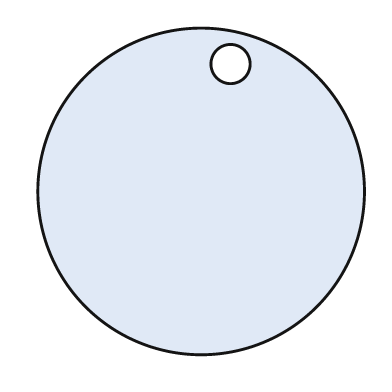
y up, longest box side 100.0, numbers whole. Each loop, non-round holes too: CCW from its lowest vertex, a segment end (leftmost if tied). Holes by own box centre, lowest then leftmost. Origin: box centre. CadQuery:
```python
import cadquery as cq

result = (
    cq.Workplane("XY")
    .moveTo(0.0, 0.0)
    .circle(50.0)
    .moveTo(9.0, 39.0)
    .circle(6.0)
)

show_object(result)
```